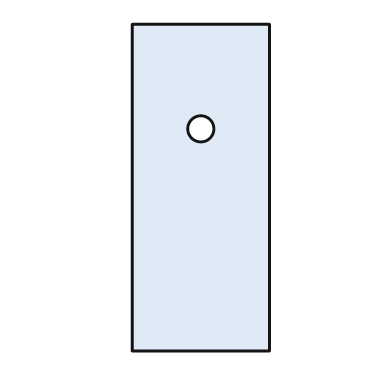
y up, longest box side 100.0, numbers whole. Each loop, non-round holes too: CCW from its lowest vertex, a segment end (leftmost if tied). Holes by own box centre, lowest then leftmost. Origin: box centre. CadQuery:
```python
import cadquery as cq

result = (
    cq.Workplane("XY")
    .moveTo(-21.0, -50.0)
    .lineTo(21.0, -50.0)
    .lineTo(21.0, 50.0)
    .lineTo(-21.0, 50.0)
    .close()
    .moveTo(0.0, 18.0)
    .circle(4.0)
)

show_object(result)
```